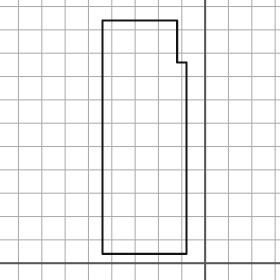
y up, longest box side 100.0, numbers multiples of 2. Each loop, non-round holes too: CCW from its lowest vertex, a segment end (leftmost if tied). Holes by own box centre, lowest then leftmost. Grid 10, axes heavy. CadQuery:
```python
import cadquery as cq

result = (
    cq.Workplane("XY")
    .moveTo(-44.0, 4.0)
    .lineTo(-8.0, 4.0)
    .lineTo(-8.0, 86.0)
    .lineTo(-12.0, 86.0)
    .lineTo(-12.0, 104.0)
    .lineTo(-44.0, 104.0)
    .close()
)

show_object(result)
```